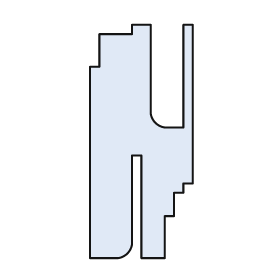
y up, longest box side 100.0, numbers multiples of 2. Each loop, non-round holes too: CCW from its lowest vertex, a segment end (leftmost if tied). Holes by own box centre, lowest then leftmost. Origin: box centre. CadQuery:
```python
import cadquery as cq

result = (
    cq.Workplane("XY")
    .moveTo(-22.0, -50.0)
    .lineTo(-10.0, -50.0)
    .threePointArc((-6.0, -48.0), (-4.0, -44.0))
    .lineTo(-4.0, -6.0)
    .lineTo(0.0, -6.0)
    .lineTo(0.0, -50.0)
    .lineTo(10.0, -50.0)
    .lineTo(10.0, -32.0)
    .lineTo(14.0, -32.0)
    .lineTo(14.0, -22.0)
    .lineTo(18.0, -22.0)
    .lineTo(18.0, -18.0)
    .lineTo(22.0, -18.0)
    .lineTo(22.0, 50.0)
    .lineTo(18.0, 50.0)
    .lineTo(18.0, 6.0)
    .lineTo(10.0, 6.0)
    .threePointArc((6.0, 8.0), (4.0, 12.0))
    .lineTo(4.0, 50.0)
    .lineTo(-4.0, 50.0)
    .lineTo(-4.0, 46.0)
    .lineTo(-18.0, 46.0)
    .lineTo(-18.0, 32.0)
    .lineTo(-22.0, 32.0)
    .close()
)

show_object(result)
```